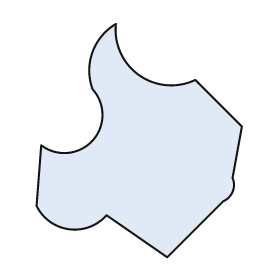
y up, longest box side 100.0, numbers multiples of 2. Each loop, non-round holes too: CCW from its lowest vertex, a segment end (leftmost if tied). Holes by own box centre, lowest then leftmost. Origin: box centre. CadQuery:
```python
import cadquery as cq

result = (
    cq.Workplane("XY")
    .moveTo(12.0, -50.0)
    .lineTo(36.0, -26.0)
    .threePointArc((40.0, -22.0), (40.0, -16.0))
    .lineTo(44.0, 6.0)
    .lineTo(24.0, 26.0)
    .threePointArc((0.0, 28.0), (-10.0, 50.0))
    .threePointArc((-20.0, 38.0), (-20.0, 22.0))
    .threePointArc((-20.0, 0.0), (-42.0, -2.0))
    .lineTo(-44.0, -28.0)
    .threePointArc((-30.0, -38.0), (-14.0, -32.0))
    .close()
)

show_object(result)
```